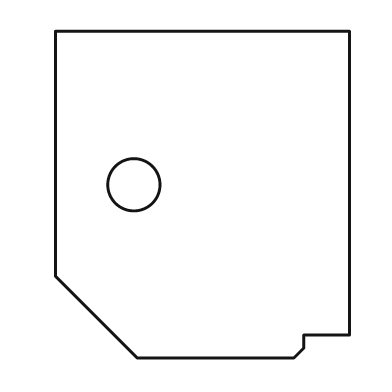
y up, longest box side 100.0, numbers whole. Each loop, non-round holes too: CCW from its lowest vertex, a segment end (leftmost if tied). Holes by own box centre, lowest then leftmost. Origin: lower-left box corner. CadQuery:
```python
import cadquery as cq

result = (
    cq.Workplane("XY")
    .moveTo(25.0, 0.0)
    .lineTo(73.0, 0.0)
    .lineTo(76.0, 3.0)
    .lineTo(76.0, 7.0)
    .lineTo(90.0, 7.0)
    .lineTo(90.0, 100.0)
    .lineTo(0.0, 100.0)
    .lineTo(0.0, 25.0)
    .close()
    .moveTo(24.0, 53.0)
    .circle(8.0)
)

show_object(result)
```